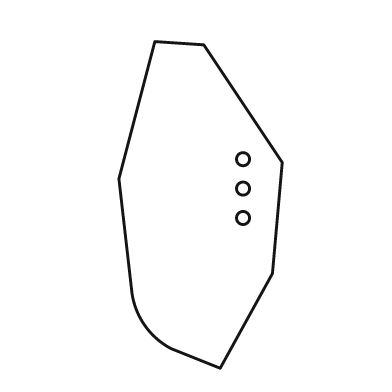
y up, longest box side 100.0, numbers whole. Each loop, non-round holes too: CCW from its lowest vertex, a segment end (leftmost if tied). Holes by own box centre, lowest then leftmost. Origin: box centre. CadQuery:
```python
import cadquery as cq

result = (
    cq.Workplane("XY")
    .moveTo(6.0, -50.0)
    .lineTo(22.0, -21.0)
    .lineTo(25.0, 13.0)
    .lineTo(1.0, 49.0)
    .lineTo(-14.0, 50.0)
    .lineTo(-25.0, 8.0)
    .lineTo(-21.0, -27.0)
    .threePointArc((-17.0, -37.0), (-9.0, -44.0))
    .close()
    .moveTo(13.0, -4.0)
    .circle(2.0)
    .moveTo(13.0, 5.0)
    .circle(2.0)
    .moveTo(13.0, 14.0)
    .circle(2.0)
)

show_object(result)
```